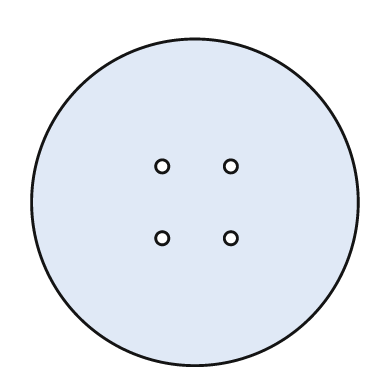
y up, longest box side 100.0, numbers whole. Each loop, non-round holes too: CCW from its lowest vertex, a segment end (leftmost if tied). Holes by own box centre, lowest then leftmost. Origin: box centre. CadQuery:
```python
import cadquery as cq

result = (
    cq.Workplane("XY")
    .moveTo(0.0, 0.0)
    .circle(50.0)
    .moveTo(-10.0, -11.0)
    .circle(2.0)
    .moveTo(11.0, -11.0)
    .circle(2.0)
    .moveTo(-10.0, 11.0)
    .circle(2.0)
    .moveTo(11.0, 11.0)
    .circle(2.0)
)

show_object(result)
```